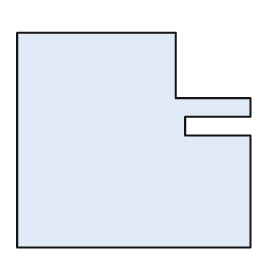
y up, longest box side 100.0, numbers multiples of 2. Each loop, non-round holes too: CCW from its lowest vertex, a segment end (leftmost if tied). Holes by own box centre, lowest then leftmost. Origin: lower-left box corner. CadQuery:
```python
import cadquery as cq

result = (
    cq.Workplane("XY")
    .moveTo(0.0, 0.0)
    .lineTo(100.0, 0.0)
    .lineTo(100.0, 48.0)
    .lineTo(72.0, 48.0)
    .lineTo(72.0, 56.0)
    .lineTo(100.0, 56.0)
    .lineTo(100.0, 64.0)
    .lineTo(68.0, 64.0)
    .lineTo(68.0, 92.0)
    .lineTo(0.0, 92.0)
    .close()
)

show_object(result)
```